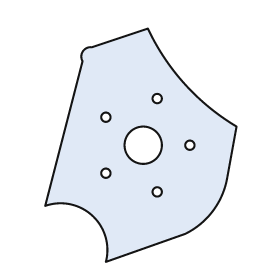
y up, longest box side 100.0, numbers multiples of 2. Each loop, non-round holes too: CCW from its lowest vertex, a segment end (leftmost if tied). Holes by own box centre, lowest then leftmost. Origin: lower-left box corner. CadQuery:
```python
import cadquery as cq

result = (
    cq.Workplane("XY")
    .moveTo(26.0, 0.0)
    .lineTo(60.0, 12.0)
    .threePointArc((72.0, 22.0), (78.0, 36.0))
    .lineTo(82.0, 58.0)
    .threePointArc((60.0, 76.0), (44.0, 100.0))
    .lineTo(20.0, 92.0)
    .threePointArc((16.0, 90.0), (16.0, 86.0))
    .lineTo(0.0, 24.0)
    .threePointArc((20.0, 20.0), (26.0, 0.0))
    .close()
    .moveTo(48.0, 30.0)
    .circle(2.0)
    .moveTo(26.0, 38.0)
    .circle(2.0)
    .moveTo(42.0, 50.0)
    .circle(8.0)
    .moveTo(62.0, 50.0)
    .circle(2.0)
    .moveTo(26.0, 62.0)
    .circle(2.0)
    .moveTo(48.0, 70.0)
    .circle(2.0)
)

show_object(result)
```